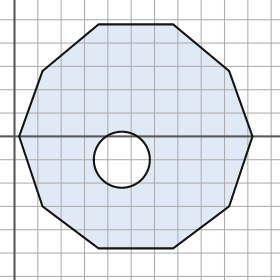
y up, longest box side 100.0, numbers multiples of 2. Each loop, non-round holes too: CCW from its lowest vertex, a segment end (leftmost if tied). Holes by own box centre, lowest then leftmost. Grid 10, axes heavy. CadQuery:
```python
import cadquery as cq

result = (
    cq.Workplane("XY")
    .moveTo(36.0, -48.0)
    .lineTo(68.0, -48.0)
    .lineTo(92.0, -30.0)
    .lineTo(102.0, 0.0)
    .lineTo(92.0, 28.0)
    .lineTo(68.0, 48.0)
    .lineTo(36.0, 48.0)
    .lineTo(12.0, 28.0)
    .lineTo(2.0, 0.0)
    .lineTo(12.0, -30.0)
    .close()
    .moveTo(46.0, -10.0)
    .circle(12.0)
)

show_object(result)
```